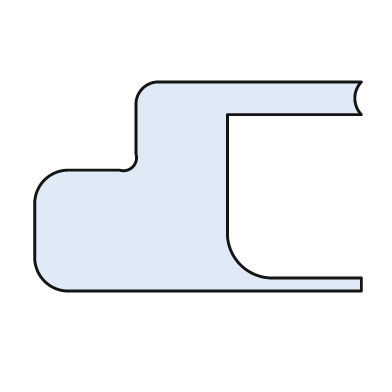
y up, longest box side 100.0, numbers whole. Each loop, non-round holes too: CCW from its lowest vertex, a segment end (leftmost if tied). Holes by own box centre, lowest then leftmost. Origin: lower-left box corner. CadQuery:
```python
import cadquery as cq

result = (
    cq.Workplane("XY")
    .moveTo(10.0, 0.0)
    .lineTo(100.0, 0.0)
    .lineTo(100.0, 4.0)
    .lineTo(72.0, 4.0)
    .threePointArc((63.0, 8.0), (59.0, 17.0))
    .lineTo(59.0, 54.0)
    .lineTo(100.0, 54.0)
    .threePointArc((98.0, 59.0), (100.0, 64.0))
    .lineTo(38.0, 64.0)
    .threePointArc((33.0, 62.0), (31.0, 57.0))
    .lineTo(31.0, 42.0)
    .threePointArc((30.0, 38.0), (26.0, 37.0))
    .lineTo(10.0, 37.0)
    .threePointArc((3.0, 34.0), (0.0, 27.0))
    .lineTo(0.0, 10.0)
    .threePointArc((3.0, 3.0), (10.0, 0.0))
    .close()
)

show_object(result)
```